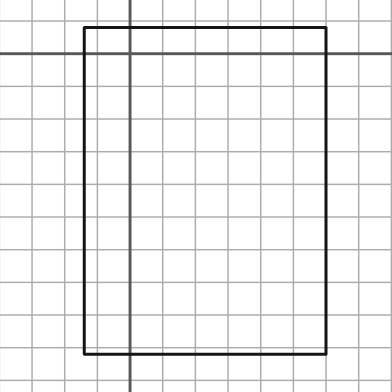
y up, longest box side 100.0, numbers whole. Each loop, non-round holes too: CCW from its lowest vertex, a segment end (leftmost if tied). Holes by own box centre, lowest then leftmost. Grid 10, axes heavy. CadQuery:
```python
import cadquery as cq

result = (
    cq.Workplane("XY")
    .moveTo(-14.0, -92.0)
    .lineTo(60.0, -92.0)
    .lineTo(60.0, 8.0)
    .lineTo(-14.0, 8.0)
    .close()
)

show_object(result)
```